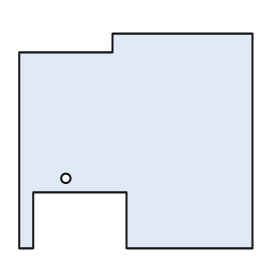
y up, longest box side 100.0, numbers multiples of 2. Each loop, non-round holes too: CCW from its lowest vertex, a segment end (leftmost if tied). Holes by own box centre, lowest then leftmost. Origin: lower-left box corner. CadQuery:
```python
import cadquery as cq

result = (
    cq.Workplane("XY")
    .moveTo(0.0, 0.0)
    .lineTo(6.0, 0.0)
    .lineTo(6.0, 24.0)
    .lineTo(46.0, 24.0)
    .lineTo(46.0, 0.0)
    .lineTo(100.0, 0.0)
    .lineTo(100.0, 92.0)
    .lineTo(40.0, 92.0)
    .lineTo(40.0, 84.0)
    .lineTo(0.0, 84.0)
    .close()
    .moveTo(20.0, 30.0)
    .circle(2.0)
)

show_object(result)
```